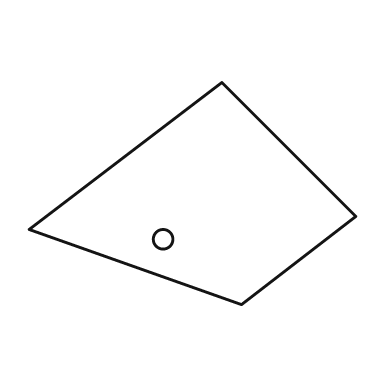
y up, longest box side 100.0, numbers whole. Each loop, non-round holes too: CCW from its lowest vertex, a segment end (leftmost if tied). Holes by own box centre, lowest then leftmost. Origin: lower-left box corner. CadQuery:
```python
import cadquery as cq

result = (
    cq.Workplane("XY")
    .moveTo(65.0, 0.0)
    .lineTo(100.0, 27.0)
    .lineTo(59.0, 68.0)
    .lineTo(0.0, 23.0)
    .close()
    .moveTo(41.0, 20.0)
    .circle(3.0)
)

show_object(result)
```